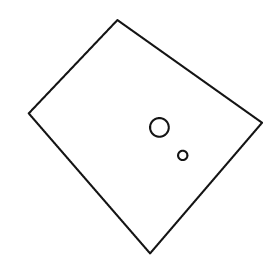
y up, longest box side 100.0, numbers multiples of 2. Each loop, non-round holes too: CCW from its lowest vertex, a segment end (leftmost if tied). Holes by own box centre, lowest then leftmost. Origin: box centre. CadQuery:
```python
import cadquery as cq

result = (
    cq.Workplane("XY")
    .moveTo(2.0, -50.0)
    .lineTo(50.0, 6.0)
    .lineTo(-12.0, 50.0)
    .lineTo(-50.0, 10.0)
    .close()
    .moveTo(16.0, -8.0)
    .circle(2.0)
    .moveTo(6.0, 4.0)
    .circle(4.0)
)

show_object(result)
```